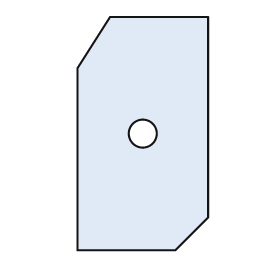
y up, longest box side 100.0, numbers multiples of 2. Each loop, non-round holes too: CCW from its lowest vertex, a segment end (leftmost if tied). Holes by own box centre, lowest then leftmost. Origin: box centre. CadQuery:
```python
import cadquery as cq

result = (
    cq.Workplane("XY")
    .moveTo(-28.0, -50.0)
    .lineTo(14.0, -50.0)
    .lineTo(28.0, -36.0)
    .lineTo(28.0, 50.0)
    .lineTo(-14.0, 50.0)
    .lineTo(-28.0, 28.0)
    .close()
    .moveTo(0.0, 0.0)
    .circle(6.0)
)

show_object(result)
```